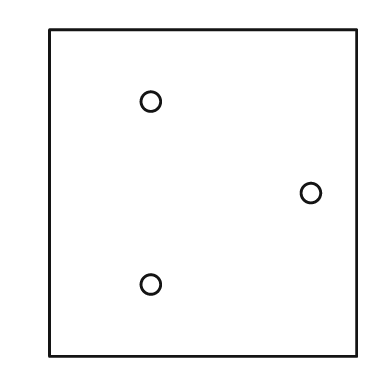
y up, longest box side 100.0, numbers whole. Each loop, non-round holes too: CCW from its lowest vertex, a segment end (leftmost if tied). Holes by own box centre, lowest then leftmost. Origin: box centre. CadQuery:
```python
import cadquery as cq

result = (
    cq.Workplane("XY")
    .moveTo(-47.0, -50.0)
    .lineTo(47.0, -50.0)
    .lineTo(47.0, 50.0)
    .lineTo(-47.0, 50.0)
    .close()
    .moveTo(-16.0, -28.0)
    .circle(3.0)
    .moveTo(33.0, 0.0)
    .circle(3.0)
    .moveTo(-16.0, 28.0)
    .circle(3.0)
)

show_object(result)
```